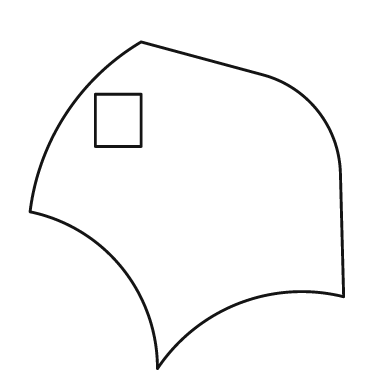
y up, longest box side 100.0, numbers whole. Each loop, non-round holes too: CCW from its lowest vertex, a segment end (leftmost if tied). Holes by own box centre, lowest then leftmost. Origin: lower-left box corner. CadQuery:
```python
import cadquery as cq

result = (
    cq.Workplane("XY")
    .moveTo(39.0, 0.0)
    .threePointArc((64.0, 20.0), (96.0, 22.0))
    .lineTo(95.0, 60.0)
    .threePointArc((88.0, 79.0), (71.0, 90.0))
    .lineTo(34.0, 100.0)
    .threePointArc((11.0, 78.0), (0.0, 48.0))
    .threePointArc((28.0, 31.0), (39.0, 0.0))
    .close()
    .moveTo(20.0, 68.0)
    .lineTo(34.0, 68.0)
    .lineTo(34.0, 84.0)
    .lineTo(20.0, 84.0)
    .close()
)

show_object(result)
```